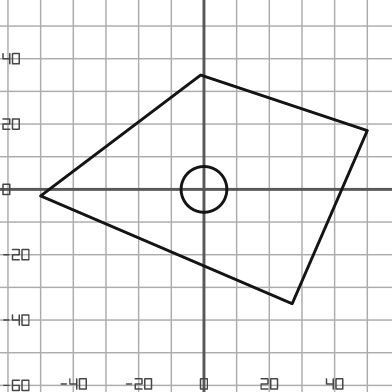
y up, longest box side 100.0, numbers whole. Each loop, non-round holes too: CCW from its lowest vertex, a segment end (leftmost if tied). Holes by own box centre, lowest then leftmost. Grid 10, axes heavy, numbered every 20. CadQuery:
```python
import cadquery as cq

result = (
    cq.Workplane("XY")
    .moveTo(27.0, -35.0)
    .lineTo(50.0, 18.0)
    .lineTo(-1.0, 35.0)
    .lineTo(-50.0, -2.0)
    .close()
    .moveTo(0.0, 0.0)
    .circle(7.0)
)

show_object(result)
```